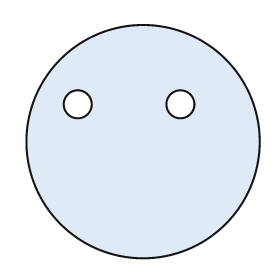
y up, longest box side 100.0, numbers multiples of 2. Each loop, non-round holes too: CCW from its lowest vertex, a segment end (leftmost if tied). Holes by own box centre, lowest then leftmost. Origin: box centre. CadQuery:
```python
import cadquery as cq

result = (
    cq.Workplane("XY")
    .moveTo(0.0, 0.0)
    .circle(50.0)
    .moveTo(-28.0, 16.0)
    .circle(6.0)
    .moveTo(16.0, 16.0)
    .circle(6.0)
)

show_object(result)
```